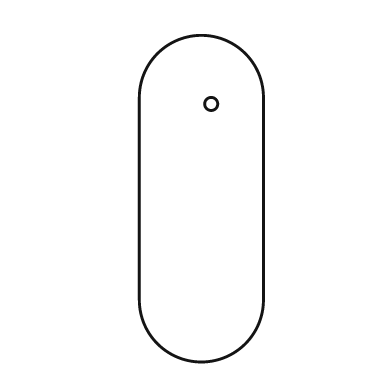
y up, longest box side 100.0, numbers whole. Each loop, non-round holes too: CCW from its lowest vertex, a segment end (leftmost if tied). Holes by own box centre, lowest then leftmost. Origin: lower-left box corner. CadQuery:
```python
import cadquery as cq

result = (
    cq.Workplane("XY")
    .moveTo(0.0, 19.0)
    .threePointArc((19.0, 0.0), (38.0, 19.0))
    .lineTo(38.0, 81.0)
    .threePointArc((19.0, 100.0), (0.0, 81.0))
    .close()
    .moveTo(22.0, 79.0)
    .circle(2.0)
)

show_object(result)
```